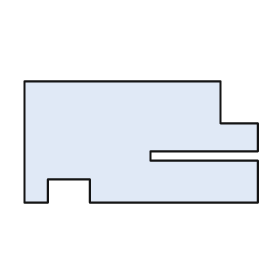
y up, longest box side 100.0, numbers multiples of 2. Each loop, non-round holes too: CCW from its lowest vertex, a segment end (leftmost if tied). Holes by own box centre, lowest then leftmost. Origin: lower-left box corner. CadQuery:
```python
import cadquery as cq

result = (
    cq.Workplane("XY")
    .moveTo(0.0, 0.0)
    .lineTo(10.0, 0.0)
    .lineTo(10.0, 10.0)
    .lineTo(28.0, 10.0)
    .lineTo(28.0, 0.0)
    .lineTo(100.0, 0.0)
    .lineTo(100.0, 18.0)
    .lineTo(54.0, 18.0)
    .lineTo(54.0, 22.0)
    .lineTo(100.0, 22.0)
    .lineTo(100.0, 34.0)
    .lineTo(84.0, 34.0)
    .lineTo(84.0, 52.0)
    .lineTo(0.0, 52.0)
    .close()
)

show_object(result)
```